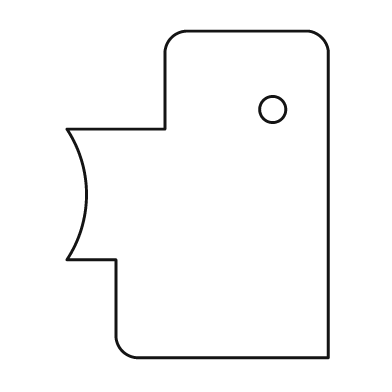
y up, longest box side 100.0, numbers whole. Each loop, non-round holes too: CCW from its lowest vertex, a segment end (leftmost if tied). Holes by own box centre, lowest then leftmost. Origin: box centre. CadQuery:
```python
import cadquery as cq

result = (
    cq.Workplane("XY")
    .moveTo(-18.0, -50.0)
    .lineTo(40.0, -50.0)
    .lineTo(40.0, 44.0)
    .threePointArc((38.0, 48.0), (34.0, 50.0))
    .lineTo(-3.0, 50.0)
    .threePointArc((-8.0, 48.0), (-10.0, 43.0))
    .lineTo(-10.0, 20.0)
    .lineTo(-40.0, 20.0)
    .threePointArc((-34.0, 0.0), (-40.0, -20.0))
    .lineTo(-25.0, -20.0)
    .lineTo(-25.0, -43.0)
    .threePointArc((-23.0, -48.0), (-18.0, -50.0))
    .close()
    .moveTo(23.0, 26.0)
    .circle(4.0)
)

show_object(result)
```